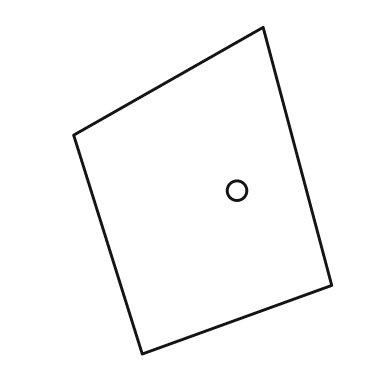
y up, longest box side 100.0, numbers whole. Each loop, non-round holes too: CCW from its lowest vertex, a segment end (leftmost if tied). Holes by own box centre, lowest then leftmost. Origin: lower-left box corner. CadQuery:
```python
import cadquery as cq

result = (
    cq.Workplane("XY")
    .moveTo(21.0, 0.0)
    .lineTo(79.0, 21.0)
    .lineTo(58.0, 100.0)
    .lineTo(0.0, 67.0)
    .close()
    .moveTo(50.0, 50.0)
    .circle(3.0)
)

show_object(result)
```